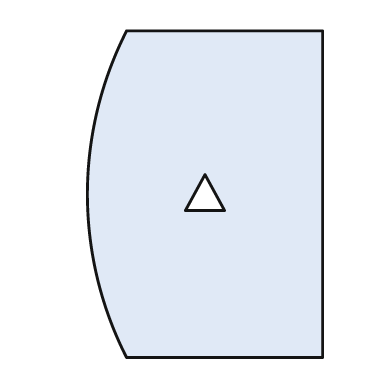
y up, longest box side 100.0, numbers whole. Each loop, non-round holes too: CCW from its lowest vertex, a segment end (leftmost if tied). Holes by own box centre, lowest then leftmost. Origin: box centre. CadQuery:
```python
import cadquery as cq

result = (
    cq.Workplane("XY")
    .moveTo(-24.0, -50.0)
    .lineTo(36.0, -50.0)
    .lineTo(36.0, 50.0)
    .lineTo(-24.0, 50.0)
    .threePointArc((-36.0, 0.0), (-24.0, -50.0))
    .close()
    .moveTo(-6.0, -5.0)
    .lineTo(6.0, -5.0)
    .lineTo(0.0, 6.0)
    .close()
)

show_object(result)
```